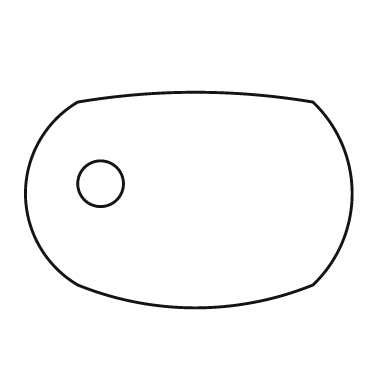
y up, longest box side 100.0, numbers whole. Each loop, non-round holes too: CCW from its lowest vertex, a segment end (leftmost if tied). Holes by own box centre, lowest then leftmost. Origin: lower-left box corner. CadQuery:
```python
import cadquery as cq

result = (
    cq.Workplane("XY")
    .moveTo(16.0, 7.0)
    .threePointArc((52.0, 0.0), (88.0, 7.0))
    .threePointArc((100.0, 35.0), (88.0, 63.0))
    .threePointArc((52.0, 66.0), (16.0, 63.0))
    .threePointArc((0.0, 35.0), (16.0, 7.0))
    .close()
    .moveTo(23.0, 38.0)
    .circle(7.0)
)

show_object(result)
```